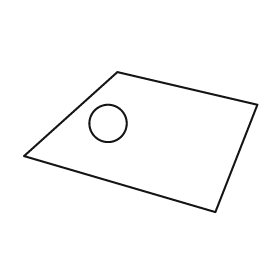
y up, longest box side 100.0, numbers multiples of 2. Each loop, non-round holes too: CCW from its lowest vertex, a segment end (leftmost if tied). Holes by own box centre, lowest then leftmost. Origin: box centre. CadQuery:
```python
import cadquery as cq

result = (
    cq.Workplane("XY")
    .moveTo(32.0, -30.0)
    .lineTo(50.0, 16.0)
    .lineTo(-10.0, 30.0)
    .lineTo(-50.0, -6.0)
    .close()
    .moveTo(-14.0, 8.0)
    .circle(8.0)
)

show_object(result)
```